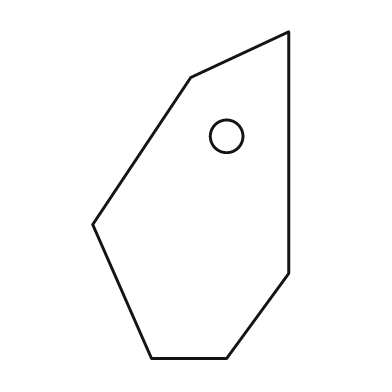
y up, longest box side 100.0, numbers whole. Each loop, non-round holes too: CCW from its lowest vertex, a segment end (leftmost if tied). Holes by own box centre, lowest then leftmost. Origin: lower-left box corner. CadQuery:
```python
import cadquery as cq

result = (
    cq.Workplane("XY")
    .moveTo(18.0, 0.0)
    .lineTo(41.0, 0.0)
    .lineTo(60.0, 26.0)
    .lineTo(60.0, 100.0)
    .lineTo(30.0, 86.0)
    .lineTo(0.0, 41.0)
    .close()
    .moveTo(41.0, 68.0)
    .circle(5.0)
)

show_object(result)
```